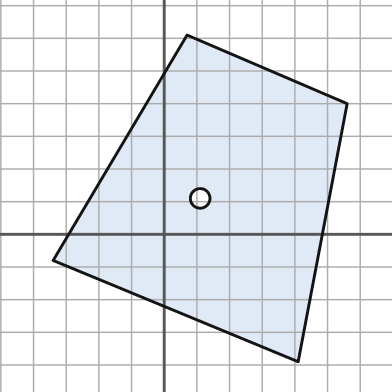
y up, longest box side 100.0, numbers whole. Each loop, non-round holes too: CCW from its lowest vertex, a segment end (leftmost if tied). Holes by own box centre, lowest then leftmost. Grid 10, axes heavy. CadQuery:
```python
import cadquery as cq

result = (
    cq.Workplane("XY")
    .moveTo(41.0, -39.0)
    .lineTo(56.0, 40.0)
    .lineTo(7.0, 61.0)
    .lineTo(-34.0, -8.0)
    .close()
    .moveTo(11.0, 11.0)
    .circle(3.0)
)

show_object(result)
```